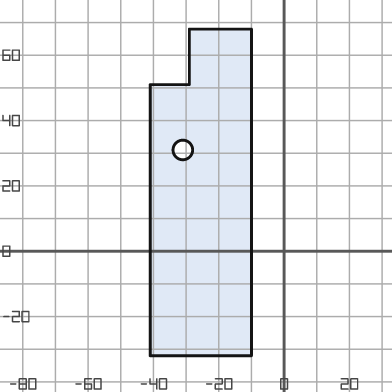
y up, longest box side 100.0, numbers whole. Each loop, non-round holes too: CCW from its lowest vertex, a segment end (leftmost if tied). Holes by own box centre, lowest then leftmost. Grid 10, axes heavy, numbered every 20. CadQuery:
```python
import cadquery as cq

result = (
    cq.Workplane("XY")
    .moveTo(-41.0, -32.0)
    .lineTo(-10.0, -32.0)
    .lineTo(-10.0, 68.0)
    .lineTo(-29.0, 68.0)
    .lineTo(-29.0, 51.0)
    .lineTo(-41.0, 51.0)
    .close()
    .moveTo(-31.0, 31.0)
    .circle(3.0)
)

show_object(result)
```